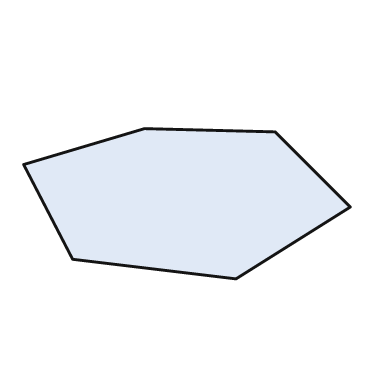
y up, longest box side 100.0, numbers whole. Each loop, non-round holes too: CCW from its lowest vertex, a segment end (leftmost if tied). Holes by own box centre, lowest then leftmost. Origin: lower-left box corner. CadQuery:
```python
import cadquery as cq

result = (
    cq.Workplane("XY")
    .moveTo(65.0, 0.0)
    .lineTo(100.0, 22.0)
    .lineTo(77.0, 45.0)
    .lineTo(37.0, 46.0)
    .lineTo(0.0, 35.0)
    .lineTo(15.0, 6.0)
    .close()
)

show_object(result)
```